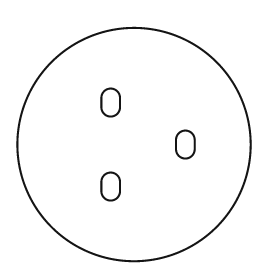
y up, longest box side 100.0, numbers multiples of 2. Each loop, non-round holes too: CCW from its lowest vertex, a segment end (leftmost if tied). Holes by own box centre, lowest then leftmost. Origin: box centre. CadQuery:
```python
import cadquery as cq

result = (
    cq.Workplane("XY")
    .moveTo(0.0, 0.0)
    .circle(50.0)
    .moveTo(-14.0, -20.0)
    .threePointArc((-10.0, -24.0), (-6.0, -20.0))
    .lineTo(-6.0, -16.0)
    .threePointArc((-10.0, -12.0), (-14.0, -16.0))
    .close()
    .moveTo(18.0, -2.0)
    .threePointArc((22.0, -6.0), (26.0, -2.0))
    .lineTo(26.0, 2.0)
    .threePointArc((22.0, 6.0), (18.0, 2.0))
    .close()
    .moveTo(-14.0, 16.0)
    .threePointArc((-10.0, 12.0), (-6.0, 16.0))
    .lineTo(-6.0, 20.0)
    .threePointArc((-10.0, 24.0), (-14.0, 20.0))
    .close()
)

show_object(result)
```